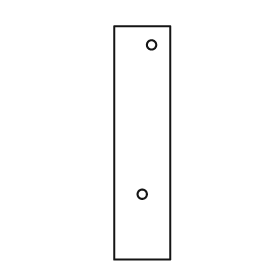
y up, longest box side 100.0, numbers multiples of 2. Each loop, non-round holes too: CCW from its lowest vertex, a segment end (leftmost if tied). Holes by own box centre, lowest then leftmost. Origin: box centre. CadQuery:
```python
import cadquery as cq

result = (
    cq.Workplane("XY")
    .moveTo(-12.0, -50.0)
    .lineTo(12.0, -50.0)
    .lineTo(12.0, 50.0)
    .lineTo(-12.0, 50.0)
    .close()
    .moveTo(0.0, -22.0)
    .circle(2.0)
    .moveTo(4.0, 42.0)
    .circle(2.0)
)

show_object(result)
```